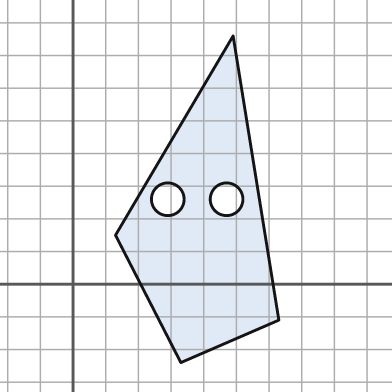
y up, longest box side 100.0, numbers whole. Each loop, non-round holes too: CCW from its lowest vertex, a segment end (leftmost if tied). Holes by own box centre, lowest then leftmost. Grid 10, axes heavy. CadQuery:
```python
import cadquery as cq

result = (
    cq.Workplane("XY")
    .moveTo(33.0, -24.0)
    .lineTo(63.0, -11.0)
    .lineTo(49.0, 76.0)
    .lineTo(13.0, 15.0)
    .close()
    .moveTo(29.0, 26.0)
    .circle(5.0)
    .moveTo(47.0, 26.0)
    .circle(5.0)
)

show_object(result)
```